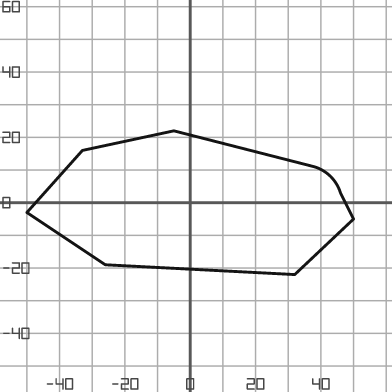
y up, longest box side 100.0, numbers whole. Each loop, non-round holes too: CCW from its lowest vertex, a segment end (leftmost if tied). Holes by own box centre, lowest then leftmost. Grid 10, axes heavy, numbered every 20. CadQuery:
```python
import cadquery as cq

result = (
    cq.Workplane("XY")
    .moveTo(32.0, -22.0)
    .lineTo(50.0, -5.0)
    .lineTo(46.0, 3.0)
    .threePointArc((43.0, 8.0), (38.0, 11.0))
    .lineTo(-5.0, 22.0)
    .lineTo(-33.0, 16.0)
    .lineTo(-50.0, -3.0)
    .lineTo(-26.0, -19.0)
    .close()
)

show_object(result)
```